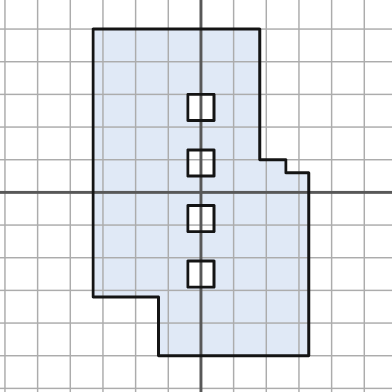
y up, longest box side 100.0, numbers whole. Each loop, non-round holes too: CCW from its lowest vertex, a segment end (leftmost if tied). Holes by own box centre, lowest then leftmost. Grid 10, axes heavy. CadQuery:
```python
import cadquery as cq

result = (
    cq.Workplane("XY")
    .moveTo(-13.0, -50.0)
    .lineTo(33.0, -50.0)
    .lineTo(33.0, 6.0)
    .lineTo(26.0, 6.0)
    .lineTo(26.0, 10.0)
    .lineTo(18.0, 10.0)
    .lineTo(18.0, 50.0)
    .lineTo(-33.0, 50.0)
    .lineTo(-33.0, -32.0)
    .lineTo(-13.0, -32.0)
    .close()
    .moveTo(-4.0, -29.0)
    .lineTo(4.0, -29.0)
    .lineTo(4.0, -21.0)
    .lineTo(-4.0, -21.0)
    .close()
    .moveTo(-4.0, -12.0)
    .lineTo(4.0, -12.0)
    .lineTo(4.0, -4.0)
    .lineTo(-4.0, -4.0)
    .close()
    .moveTo(-4.0, 5.0)
    .lineTo(4.0, 5.0)
    .lineTo(4.0, 13.0)
    .lineTo(-4.0, 13.0)
    .close()
    .moveTo(-4.0, 22.0)
    .lineTo(4.0, 22.0)
    .lineTo(4.0, 30.0)
    .lineTo(-4.0, 30.0)
    .close()
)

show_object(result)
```